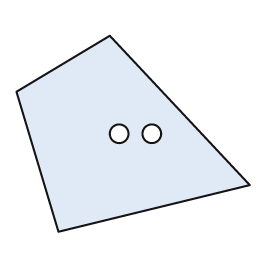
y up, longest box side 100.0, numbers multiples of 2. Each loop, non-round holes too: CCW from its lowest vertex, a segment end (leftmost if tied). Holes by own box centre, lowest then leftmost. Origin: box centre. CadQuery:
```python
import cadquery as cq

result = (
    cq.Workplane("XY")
    .moveTo(-32.0, -42.0)
    .lineTo(50.0, -22.0)
    .lineTo(-10.0, 42.0)
    .lineTo(-50.0, 18.0)
    .close()
    .moveTo(-6.0, 0.0)
    .circle(4.0)
    .moveTo(8.0, 0.0)
    .circle(4.0)
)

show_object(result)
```